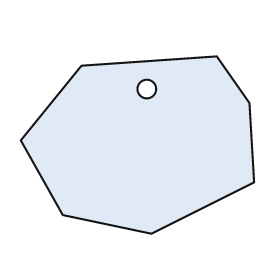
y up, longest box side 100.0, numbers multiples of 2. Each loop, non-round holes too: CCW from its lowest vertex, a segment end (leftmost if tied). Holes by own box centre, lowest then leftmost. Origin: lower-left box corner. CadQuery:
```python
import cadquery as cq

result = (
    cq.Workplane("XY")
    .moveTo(56.0, 0.0)
    .lineTo(100.0, 22.0)
    .lineTo(98.0, 56.0)
    .lineTo(84.0, 76.0)
    .lineTo(26.0, 72.0)
    .lineTo(0.0, 40.0)
    .lineTo(18.0, 8.0)
    .close()
    .moveTo(54.0, 62.0)
    .circle(4.0)
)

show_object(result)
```